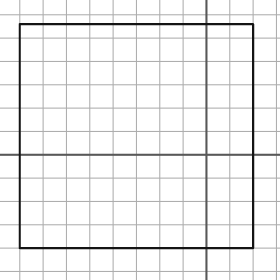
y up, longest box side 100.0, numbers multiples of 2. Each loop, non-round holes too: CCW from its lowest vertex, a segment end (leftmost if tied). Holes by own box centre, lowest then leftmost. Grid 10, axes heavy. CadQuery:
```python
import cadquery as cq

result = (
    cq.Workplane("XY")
    .moveTo(-80.0, -40.0)
    .lineTo(20.0, -40.0)
    .lineTo(20.0, 56.0)
    .lineTo(-80.0, 56.0)
    .close()
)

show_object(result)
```